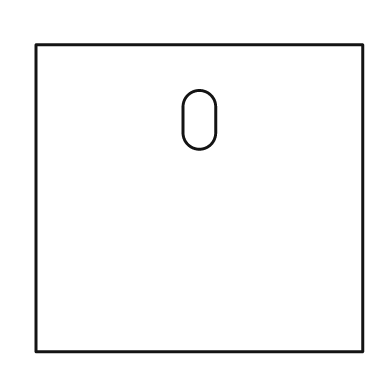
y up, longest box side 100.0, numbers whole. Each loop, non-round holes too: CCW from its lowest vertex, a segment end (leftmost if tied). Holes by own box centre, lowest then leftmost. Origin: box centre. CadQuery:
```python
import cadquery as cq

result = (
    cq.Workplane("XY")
    .moveTo(-50.0, -47.0)
    .lineTo(50.0, -47.0)
    .lineTo(50.0, 47.0)
    .lineTo(-50.0, 47.0)
    .close()
    .moveTo(-5.0, 20.0)
    .threePointArc((0.0, 15.0), (5.0, 20.0))
    .lineTo(5.0, 28.0)
    .threePointArc((0.0, 33.0), (-5.0, 28.0))
    .close()
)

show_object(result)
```